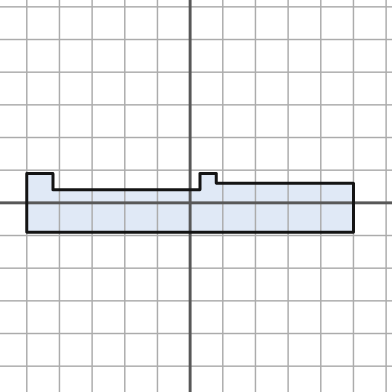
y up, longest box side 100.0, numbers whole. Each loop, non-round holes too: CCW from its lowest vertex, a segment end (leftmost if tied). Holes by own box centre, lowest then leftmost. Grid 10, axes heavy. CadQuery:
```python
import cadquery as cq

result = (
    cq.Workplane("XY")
    .moveTo(-50.0, -9.0)
    .lineTo(50.0, -9.0)
    .lineTo(50.0, 6.0)
    .lineTo(8.0, 6.0)
    .lineTo(8.0, 9.0)
    .lineTo(3.0, 9.0)
    .lineTo(3.0, 4.0)
    .lineTo(-42.0, 4.0)
    .lineTo(-42.0, 9.0)
    .lineTo(-50.0, 9.0)
    .close()
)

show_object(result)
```